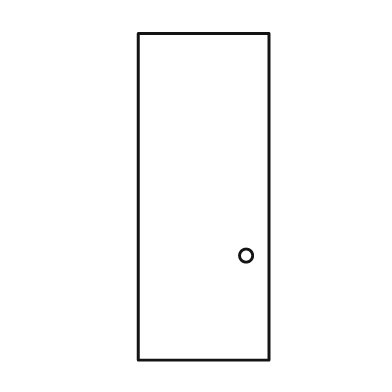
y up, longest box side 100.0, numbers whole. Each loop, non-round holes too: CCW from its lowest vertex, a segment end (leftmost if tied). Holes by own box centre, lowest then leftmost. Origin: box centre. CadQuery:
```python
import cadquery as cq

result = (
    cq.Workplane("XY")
    .moveTo(-20.0, -50.0)
    .lineTo(20.0, -50.0)
    .lineTo(20.0, 50.0)
    .lineTo(-20.0, 50.0)
    .close()
    .moveTo(13.0, -18.0)
    .circle(2.0)
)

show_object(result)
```